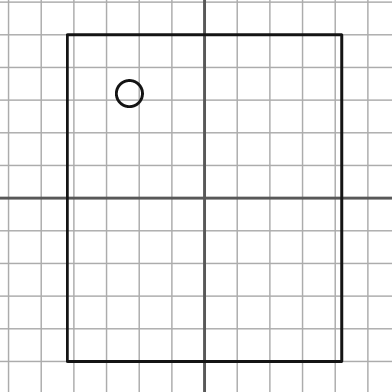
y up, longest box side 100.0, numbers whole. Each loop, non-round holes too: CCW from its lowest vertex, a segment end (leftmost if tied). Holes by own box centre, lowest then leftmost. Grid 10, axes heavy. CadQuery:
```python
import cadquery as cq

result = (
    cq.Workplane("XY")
    .moveTo(-42.0, -50.0)
    .lineTo(42.0, -50.0)
    .lineTo(42.0, 50.0)
    .lineTo(-42.0, 50.0)
    .close()
    .moveTo(-23.0, 32.0)
    .circle(4.0)
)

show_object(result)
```